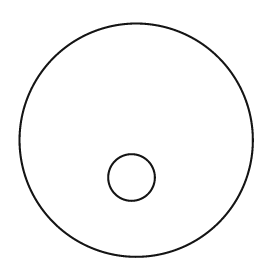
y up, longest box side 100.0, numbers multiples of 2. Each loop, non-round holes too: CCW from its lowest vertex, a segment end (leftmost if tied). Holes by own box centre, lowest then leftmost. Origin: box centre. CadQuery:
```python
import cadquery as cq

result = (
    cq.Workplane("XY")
    .moveTo(0.0, 0.0)
    .circle(50.0)
    .moveTo(-2.0, -16.0)
    .circle(10.0)
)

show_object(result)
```